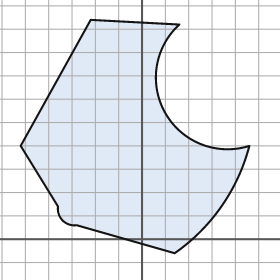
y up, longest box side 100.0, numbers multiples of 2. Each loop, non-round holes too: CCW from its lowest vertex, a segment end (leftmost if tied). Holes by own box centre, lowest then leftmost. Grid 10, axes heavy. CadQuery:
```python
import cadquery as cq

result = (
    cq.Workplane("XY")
    .moveTo(14.0, -6.0)
    .threePointArc((34.0, 14.0), (46.0, 40.0))
    .threePointArc((10.0, 54.0), (16.0, 92.0))
    .lineTo(-22.0, 94.0)
    .lineTo(-52.0, 40.0)
    .lineTo(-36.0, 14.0)
    .threePointArc((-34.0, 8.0), (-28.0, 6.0))
    .close()
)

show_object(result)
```